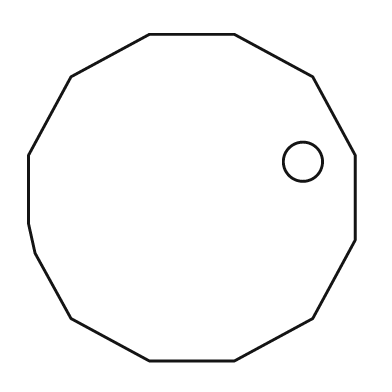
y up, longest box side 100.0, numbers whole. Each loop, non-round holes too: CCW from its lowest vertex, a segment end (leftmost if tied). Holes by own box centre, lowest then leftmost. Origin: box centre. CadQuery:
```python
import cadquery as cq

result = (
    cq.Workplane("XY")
    .moveTo(-13.0, -50.0)
    .lineTo(13.0, -50.0)
    .lineTo(37.0, -37.0)
    .lineTo(50.0, -13.0)
    .lineTo(50.0, 13.0)
    .lineTo(37.0, 37.0)
    .lineTo(13.0, 50.0)
    .lineTo(-13.0, 50.0)
    .lineTo(-37.0, 37.0)
    .lineTo(-50.0, 13.0)
    .lineTo(-50.0, -8.0)
    .lineTo(-48.0, -17.0)
    .lineTo(-37.0, -37.0)
    .close()
    .moveTo(34.0, 11.0)
    .circle(6.0)
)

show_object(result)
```